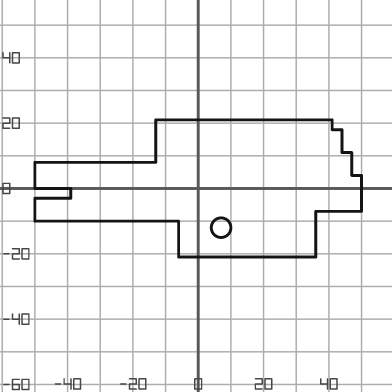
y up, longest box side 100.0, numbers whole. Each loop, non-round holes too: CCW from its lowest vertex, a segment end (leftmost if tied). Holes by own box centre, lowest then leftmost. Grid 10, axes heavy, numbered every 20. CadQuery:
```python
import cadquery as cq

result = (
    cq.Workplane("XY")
    .moveTo(-6.0, -21.0)
    .lineTo(36.0, -21.0)
    .lineTo(36.0, -7.0)
    .lineTo(50.0, -7.0)
    .lineTo(50.0, 4.0)
    .lineTo(47.0, 4.0)
    .lineTo(47.0, 11.0)
    .lineTo(44.0, 11.0)
    .lineTo(44.0, 18.0)
    .lineTo(41.0, 18.0)
    .lineTo(41.0, 21.0)
    .lineTo(-13.0, 21.0)
    .lineTo(-13.0, 8.0)
    .lineTo(-50.0, 8.0)
    .lineTo(-50.0, 0.0)
    .lineTo(-39.0, 0.0)
    .lineTo(-39.0, -3.0)
    .lineTo(-50.0, -3.0)
    .lineTo(-50.0, -10.0)
    .lineTo(-6.0, -10.0)
    .close()
    .moveTo(7.0, -12.0)
    .circle(3.0)
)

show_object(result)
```